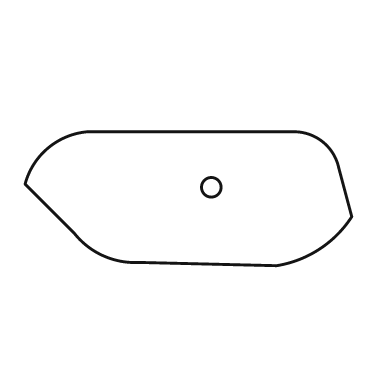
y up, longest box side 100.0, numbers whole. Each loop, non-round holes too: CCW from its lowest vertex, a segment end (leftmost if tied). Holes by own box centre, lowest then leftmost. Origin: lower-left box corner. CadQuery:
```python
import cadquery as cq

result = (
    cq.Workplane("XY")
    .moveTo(77.0, 0.0)
    .threePointArc((90.0, 5.0), (100.0, 15.0))
    .lineTo(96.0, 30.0)
    .threePointArc((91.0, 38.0), (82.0, 41.0))
    .lineTo(19.0, 41.0)
    .threePointArc((7.0, 36.0), (0.0, 25.0))
    .lineTo(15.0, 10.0)
    .threePointArc((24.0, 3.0), (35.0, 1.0))
    .close()
    .moveTo(57.0, 24.0)
    .circle(3.0)
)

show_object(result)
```